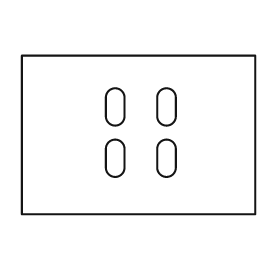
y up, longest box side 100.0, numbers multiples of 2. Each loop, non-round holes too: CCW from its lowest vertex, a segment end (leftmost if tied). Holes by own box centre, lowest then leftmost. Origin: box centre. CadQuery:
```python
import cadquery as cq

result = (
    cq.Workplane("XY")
    .moveTo(-50.0, -34.0)
    .lineTo(50.0, -34.0)
    .lineTo(50.0, 34.0)
    .lineTo(-50.0, 34.0)
    .close()
    .moveTo(-14.0, -14.0)
    .threePointArc((-10.0, -18.0), (-6.0, -14.0))
    .lineTo(-6.0, -6.0)
    .threePointArc((-10.0, -2.0), (-14.0, -6.0))
    .close()
    .moveTo(8.0, -14.0)
    .threePointArc((12.0, -18.0), (16.0, -14.0))
    .lineTo(16.0, -6.0)
    .threePointArc((12.0, -2.0), (8.0, -6.0))
    .close()
    .moveTo(-14.0, 8.0)
    .threePointArc((-10.0, 4.0), (-6.0, 8.0))
    .lineTo(-6.0, 16.0)
    .threePointArc((-10.0, 20.0), (-14.0, 16.0))
    .close()
    .moveTo(8.0, 8.0)
    .threePointArc((12.0, 4.0), (16.0, 8.0))
    .lineTo(16.0, 16.0)
    .threePointArc((12.0, 20.0), (8.0, 16.0))
    .close()
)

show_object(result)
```